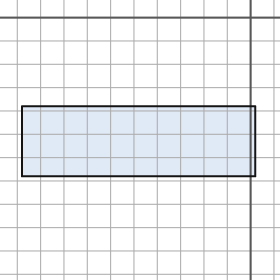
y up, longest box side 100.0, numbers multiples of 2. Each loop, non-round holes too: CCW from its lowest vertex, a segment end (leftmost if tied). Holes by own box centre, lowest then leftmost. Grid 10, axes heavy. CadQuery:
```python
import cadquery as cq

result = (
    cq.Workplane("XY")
    .moveTo(-98.0, -68.0)
    .lineTo(2.0, -68.0)
    .lineTo(2.0, -38.0)
    .lineTo(-98.0, -38.0)
    .close()
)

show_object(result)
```